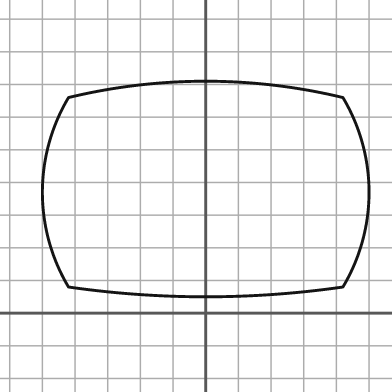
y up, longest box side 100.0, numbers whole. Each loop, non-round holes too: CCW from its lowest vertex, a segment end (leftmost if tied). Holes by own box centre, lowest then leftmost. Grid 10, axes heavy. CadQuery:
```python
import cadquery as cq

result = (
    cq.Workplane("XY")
    .moveTo(-42.0, 8.0)
    .threePointArc((0.0, 5.0), (42.0, 8.0))
    .threePointArc((50.0, 37.0), (42.0, 66.0))
    .threePointArc((0.0, 71.0), (-42.0, 66.0))
    .threePointArc((-50.0, 37.0), (-42.0, 8.0))
    .close()
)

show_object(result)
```